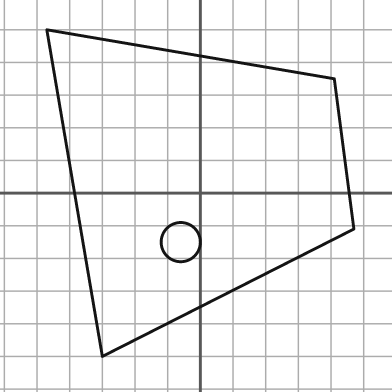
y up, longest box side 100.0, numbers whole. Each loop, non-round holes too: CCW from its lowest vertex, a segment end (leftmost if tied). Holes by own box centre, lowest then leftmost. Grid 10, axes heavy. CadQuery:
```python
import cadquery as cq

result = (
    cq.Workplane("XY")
    .moveTo(-30.0, -50.0)
    .lineTo(47.0, -11.0)
    .lineTo(41.0, 35.0)
    .lineTo(-47.0, 50.0)
    .close()
    .moveTo(-6.0, -15.0)
    .circle(6.0)
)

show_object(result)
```